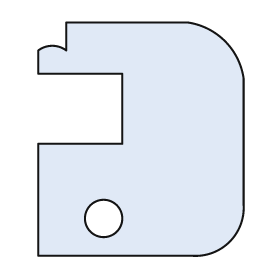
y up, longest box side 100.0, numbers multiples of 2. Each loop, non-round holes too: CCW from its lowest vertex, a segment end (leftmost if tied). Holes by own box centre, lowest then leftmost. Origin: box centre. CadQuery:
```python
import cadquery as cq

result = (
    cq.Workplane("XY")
    .moveTo(-44.0, -50.0)
    .lineTo(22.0, -50.0)
    .threePointArc((38.0, -44.0), (44.0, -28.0))
    .lineTo(44.0, 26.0)
    .threePointArc((36.0, 42.0), (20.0, 50.0))
    .lineTo(-32.0, 50.0)
    .lineTo(-32.0, 38.0)
    .threePointArc((-38.0, 40.0), (-44.0, 38.0))
    .lineTo(-44.0, 28.0)
    .lineTo(-8.0, 28.0)
    .lineTo(-8.0, -2.0)
    .lineTo(-44.0, -2.0)
    .close()
    .moveTo(-16.0, -34.0)
    .circle(8.0)
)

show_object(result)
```